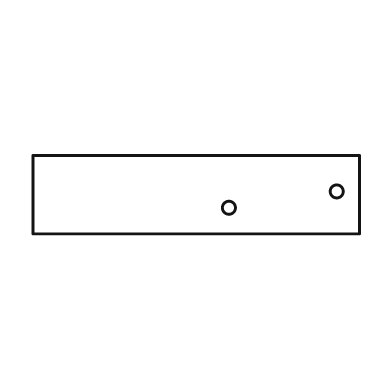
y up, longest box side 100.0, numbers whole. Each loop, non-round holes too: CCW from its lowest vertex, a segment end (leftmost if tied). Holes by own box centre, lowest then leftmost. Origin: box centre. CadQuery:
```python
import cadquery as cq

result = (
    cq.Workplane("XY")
    .moveTo(-50.0, -12.0)
    .lineTo(50.0, -12.0)
    .lineTo(50.0, 12.0)
    .lineTo(-50.0, 12.0)
    .close()
    .moveTo(10.0, -4.0)
    .circle(2.0)
    .moveTo(43.0, 1.0)
    .circle(2.0)
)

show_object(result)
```